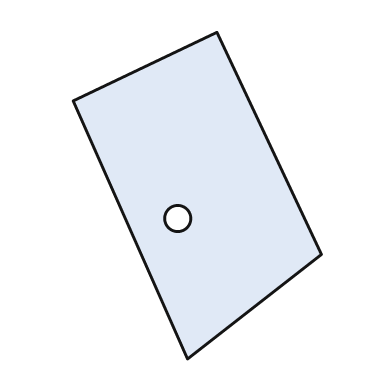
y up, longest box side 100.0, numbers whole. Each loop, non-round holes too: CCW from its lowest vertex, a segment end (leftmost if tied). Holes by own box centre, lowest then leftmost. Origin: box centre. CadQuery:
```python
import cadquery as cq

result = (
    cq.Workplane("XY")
    .moveTo(-3.0, -50.0)
    .lineTo(38.0, -18.0)
    .lineTo(6.0, 50.0)
    .lineTo(-38.0, 29.0)
    .close()
    .moveTo(-6.0, -7.0)
    .circle(4.0)
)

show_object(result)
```